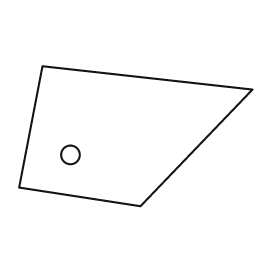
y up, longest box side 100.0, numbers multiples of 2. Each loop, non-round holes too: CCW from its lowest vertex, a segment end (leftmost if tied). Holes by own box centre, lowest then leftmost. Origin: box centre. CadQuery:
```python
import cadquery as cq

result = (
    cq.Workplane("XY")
    .moveTo(2.0, -30.0)
    .lineTo(50.0, 20.0)
    .lineTo(-40.0, 30.0)
    .lineTo(-50.0, -22.0)
    .close()
    .moveTo(-28.0, -8.0)
    .circle(4.0)
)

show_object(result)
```